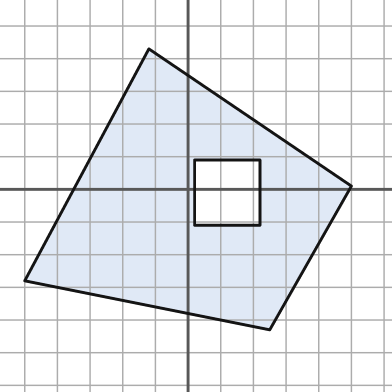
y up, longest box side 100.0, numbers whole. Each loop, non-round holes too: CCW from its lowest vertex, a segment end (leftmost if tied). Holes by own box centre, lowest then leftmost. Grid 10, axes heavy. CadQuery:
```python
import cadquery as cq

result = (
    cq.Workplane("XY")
    .moveTo(25.0, -43.0)
    .lineTo(50.0, 1.0)
    .lineTo(-12.0, 43.0)
    .lineTo(-50.0, -28.0)
    .close()
    .moveTo(2.0, -11.0)
    .lineTo(22.0, -11.0)
    .lineTo(22.0, 9.0)
    .lineTo(2.0, 9.0)
    .close()
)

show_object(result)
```